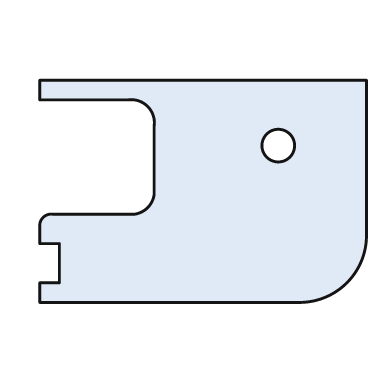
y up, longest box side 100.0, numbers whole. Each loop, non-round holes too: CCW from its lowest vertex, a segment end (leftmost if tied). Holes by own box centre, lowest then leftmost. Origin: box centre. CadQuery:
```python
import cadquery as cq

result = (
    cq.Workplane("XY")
    .moveTo(-50.0, -34.0)
    .lineTo(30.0, -34.0)
    .threePointArc((44.0, -28.0), (50.0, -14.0))
    .lineTo(50.0, 34.0)
    .lineTo(-50.0, 34.0)
    .lineTo(-50.0, 28.0)
    .lineTo(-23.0, 28.0)
    .threePointArc((-17.0, 26.0), (-15.0, 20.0))
    .lineTo(-15.0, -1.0)
    .threePointArc((-17.0, -5.0), (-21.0, -7.0))
    .lineTo(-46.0, -7.0)
    .threePointArc((-49.0, -8.0), (-50.0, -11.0))
    .lineTo(-50.0, -16.0)
    .lineTo(-44.0, -16.0)
    .lineTo(-44.0, -28.0)
    .lineTo(-50.0, -28.0)
    .close()
    .moveTo(23.0, 14.0)
    .circle(5.0)
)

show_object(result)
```